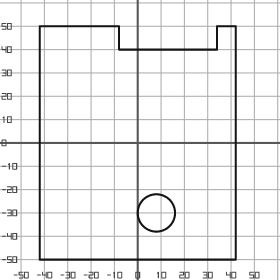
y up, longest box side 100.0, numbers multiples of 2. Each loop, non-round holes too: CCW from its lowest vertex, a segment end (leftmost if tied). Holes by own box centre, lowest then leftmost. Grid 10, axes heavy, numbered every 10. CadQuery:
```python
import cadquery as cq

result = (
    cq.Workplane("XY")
    .moveTo(-42.0, -50.0)
    .lineTo(42.0, -50.0)
    .lineTo(42.0, 50.0)
    .lineTo(34.0, 50.0)
    .lineTo(34.0, 40.0)
    .lineTo(-8.0, 40.0)
    .lineTo(-8.0, 50.0)
    .lineTo(-42.0, 50.0)
    .close()
    .moveTo(8.0, -30.0)
    .circle(8.0)
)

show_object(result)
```